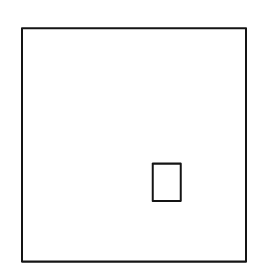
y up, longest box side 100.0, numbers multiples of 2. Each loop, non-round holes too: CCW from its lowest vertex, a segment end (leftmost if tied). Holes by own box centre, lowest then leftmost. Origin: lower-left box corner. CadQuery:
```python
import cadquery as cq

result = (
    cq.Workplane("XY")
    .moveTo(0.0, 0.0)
    .lineTo(96.0, 0.0)
    .lineTo(96.0, 100.0)
    .lineTo(0.0, 100.0)
    .close()
    .moveTo(56.0, 26.0)
    .lineTo(68.0, 26.0)
    .lineTo(68.0, 42.0)
    .lineTo(56.0, 42.0)
    .close()
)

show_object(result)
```